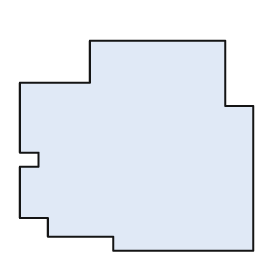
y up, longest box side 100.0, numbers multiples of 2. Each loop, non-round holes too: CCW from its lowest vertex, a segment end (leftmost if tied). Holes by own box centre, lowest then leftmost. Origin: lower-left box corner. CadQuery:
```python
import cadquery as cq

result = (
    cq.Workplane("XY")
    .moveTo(40.0, 0.0)
    .lineTo(100.0, 0.0)
    .lineTo(100.0, 62.0)
    .lineTo(88.0, 62.0)
    .lineTo(88.0, 90.0)
    .lineTo(30.0, 90.0)
    .lineTo(30.0, 72.0)
    .lineTo(0.0, 72.0)
    .lineTo(0.0, 42.0)
    .lineTo(8.0, 42.0)
    .lineTo(8.0, 36.0)
    .lineTo(0.0, 36.0)
    .lineTo(0.0, 14.0)
    .lineTo(12.0, 14.0)
    .lineTo(12.0, 6.0)
    .lineTo(40.0, 6.0)
    .close()
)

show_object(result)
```